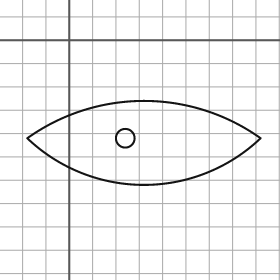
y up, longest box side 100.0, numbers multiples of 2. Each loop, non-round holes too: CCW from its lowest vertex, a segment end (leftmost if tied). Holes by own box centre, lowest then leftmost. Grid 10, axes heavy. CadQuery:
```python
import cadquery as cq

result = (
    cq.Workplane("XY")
    .moveTo(-18.0, -42.0)
    .threePointArc((32.0, -62.0), (82.0, -42.0))
    .threePointArc((32.0, -26.0), (-18.0, -42.0))
    .close()
    .moveTo(24.0, -42.0)
    .circle(4.0)
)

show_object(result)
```